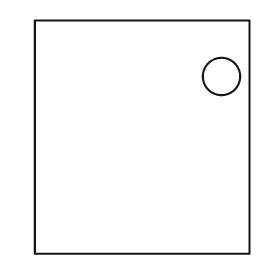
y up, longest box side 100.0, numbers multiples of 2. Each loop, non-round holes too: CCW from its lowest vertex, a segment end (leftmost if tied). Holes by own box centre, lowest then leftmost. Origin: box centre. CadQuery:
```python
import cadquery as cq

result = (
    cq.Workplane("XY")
    .moveTo(-46.0, -50.0)
    .lineTo(46.0, -50.0)
    .lineTo(46.0, 50.0)
    .lineTo(-46.0, 50.0)
    .close()
    .moveTo(34.0, 26.0)
    .circle(8.0)
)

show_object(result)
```